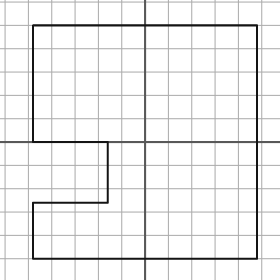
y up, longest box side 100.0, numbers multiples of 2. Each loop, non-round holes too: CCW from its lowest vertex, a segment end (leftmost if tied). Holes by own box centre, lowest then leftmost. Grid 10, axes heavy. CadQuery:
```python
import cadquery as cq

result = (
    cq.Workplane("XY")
    .moveTo(-48.0, -50.0)
    .lineTo(48.0, -50.0)
    .lineTo(48.0, 50.0)
    .lineTo(-48.0, 50.0)
    .lineTo(-48.0, 0.0)
    .lineTo(-16.0, 0.0)
    .lineTo(-16.0, -26.0)
    .lineTo(-48.0, -26.0)
    .close()
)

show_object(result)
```